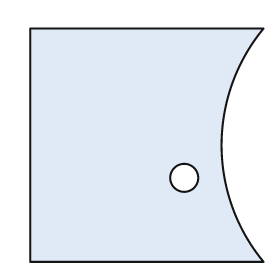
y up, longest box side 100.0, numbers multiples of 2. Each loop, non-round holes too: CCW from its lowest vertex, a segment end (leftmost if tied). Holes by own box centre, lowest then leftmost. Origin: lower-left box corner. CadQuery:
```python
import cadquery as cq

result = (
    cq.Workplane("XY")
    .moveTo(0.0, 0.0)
    .lineTo(100.0, 0.0)
    .threePointArc((82.0, 50.0), (100.0, 100.0))
    .lineTo(0.0, 100.0)
    .close()
    .moveTo(66.0, 36.0)
    .circle(6.0)
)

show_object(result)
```